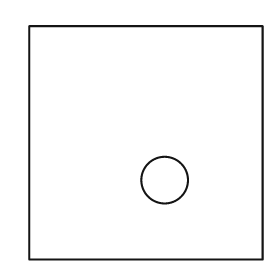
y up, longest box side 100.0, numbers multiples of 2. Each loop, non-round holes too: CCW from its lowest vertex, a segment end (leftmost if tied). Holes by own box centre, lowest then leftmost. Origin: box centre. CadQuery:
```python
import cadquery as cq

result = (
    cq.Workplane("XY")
    .moveTo(-50.0, -50.0)
    .lineTo(50.0, -50.0)
    .lineTo(50.0, 50.0)
    .lineTo(-50.0, 50.0)
    .close()
    .moveTo(8.0, -16.0)
    .circle(10.0)
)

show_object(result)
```